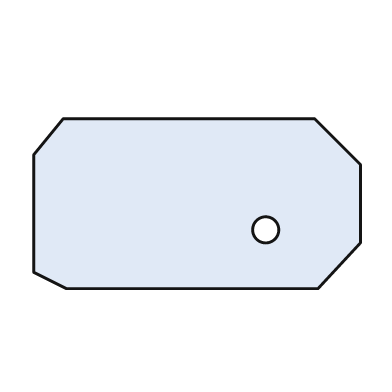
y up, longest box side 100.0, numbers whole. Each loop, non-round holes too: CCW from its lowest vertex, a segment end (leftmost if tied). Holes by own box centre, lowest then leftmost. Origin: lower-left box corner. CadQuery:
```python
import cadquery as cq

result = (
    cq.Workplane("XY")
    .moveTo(10.0, 0.0)
    .lineTo(87.0, 0.0)
    .lineTo(100.0, 14.0)
    .lineTo(100.0, 38.0)
    .lineTo(86.0, 52.0)
    .lineTo(9.0, 52.0)
    .lineTo(0.0, 41.0)
    .lineTo(0.0, 5.0)
    .close()
    .moveTo(71.0, 18.0)
    .circle(4.0)
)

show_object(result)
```